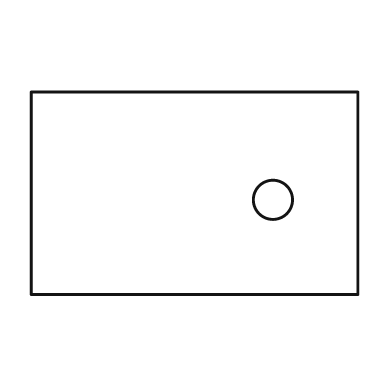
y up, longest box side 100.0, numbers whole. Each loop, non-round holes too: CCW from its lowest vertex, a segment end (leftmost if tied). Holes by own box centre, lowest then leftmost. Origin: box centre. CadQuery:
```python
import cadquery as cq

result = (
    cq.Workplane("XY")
    .moveTo(-50.0, -31.0)
    .lineTo(50.0, -31.0)
    .lineTo(50.0, 31.0)
    .lineTo(-50.0, 31.0)
    .close()
    .moveTo(24.0, -2.0)
    .circle(6.0)
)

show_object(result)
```